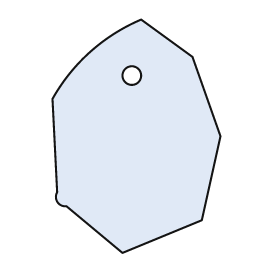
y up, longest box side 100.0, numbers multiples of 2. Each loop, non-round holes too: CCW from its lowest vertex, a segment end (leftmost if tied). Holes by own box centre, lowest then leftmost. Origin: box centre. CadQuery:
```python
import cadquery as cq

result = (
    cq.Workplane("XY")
    .moveTo(-6.0, -50.0)
    .lineTo(28.0, -36.0)
    .lineTo(36.0, 0.0)
    .lineTo(24.0, 34.0)
    .lineTo(2.0, 50.0)
    .threePointArc((-20.0, 36.0), (-36.0, 16.0))
    .lineTo(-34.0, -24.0)
    .threePointArc((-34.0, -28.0), (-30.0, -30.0))
    .close()
    .moveTo(-2.0, 26.0)
    .circle(4.0)
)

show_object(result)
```